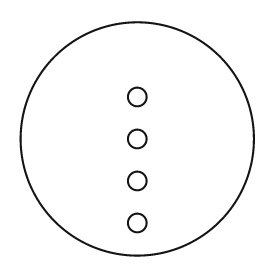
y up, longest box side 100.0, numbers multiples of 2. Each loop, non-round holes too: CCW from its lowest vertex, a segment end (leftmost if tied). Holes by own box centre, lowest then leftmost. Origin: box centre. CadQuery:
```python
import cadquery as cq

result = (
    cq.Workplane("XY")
    .moveTo(0.0, 0.0)
    .circle(50.0)
    .moveTo(0.0, -36.0)
    .circle(4.0)
    .moveTo(0.0, -18.0)
    .circle(4.0)
    .moveTo(0.0, 0.0)
    .circle(4.0)
    .moveTo(0.0, 18.0)
    .circle(4.0)
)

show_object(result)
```